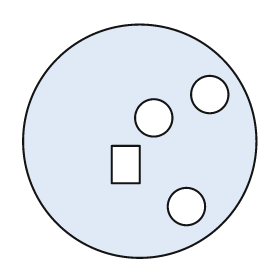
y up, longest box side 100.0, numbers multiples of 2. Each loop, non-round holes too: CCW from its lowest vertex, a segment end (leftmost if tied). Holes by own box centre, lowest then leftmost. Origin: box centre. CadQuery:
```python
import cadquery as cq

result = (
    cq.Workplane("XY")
    .moveTo(0.0, 0.0)
    .circle(50.0)
    .moveTo(20.0, -28.0)
    .circle(8.0)
    .moveTo(-12.0, -18.0)
    .lineTo(0.0, -18.0)
    .lineTo(0.0, -2.0)
    .lineTo(-12.0, -2.0)
    .close()
    .moveTo(6.0, 10.0)
    .circle(8.0)
    .moveTo(30.0, 20.0)
    .circle(8.0)
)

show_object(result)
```